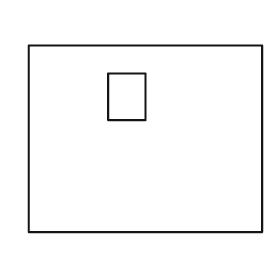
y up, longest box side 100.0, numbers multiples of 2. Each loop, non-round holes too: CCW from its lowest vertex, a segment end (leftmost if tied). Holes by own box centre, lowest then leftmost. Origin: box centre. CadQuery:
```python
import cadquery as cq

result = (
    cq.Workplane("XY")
    .moveTo(-50.0, -40.0)
    .lineTo(50.0, -40.0)
    .lineTo(50.0, 40.0)
    .lineTo(-50.0, 40.0)
    .close()
    .moveTo(-16.0, 8.0)
    .lineTo(0.0, 8.0)
    .lineTo(0.0, 28.0)
    .lineTo(-16.0, 28.0)
    .close()
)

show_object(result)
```